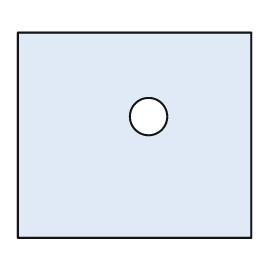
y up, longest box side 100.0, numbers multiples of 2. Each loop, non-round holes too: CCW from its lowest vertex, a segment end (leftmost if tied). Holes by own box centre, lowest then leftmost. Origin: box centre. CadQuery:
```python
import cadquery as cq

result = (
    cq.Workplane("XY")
    .moveTo(-50.0, -44.0)
    .lineTo(50.0, -44.0)
    .lineTo(50.0, 44.0)
    .lineTo(-50.0, 44.0)
    .close()
    .moveTo(6.0, 8.0)
    .circle(8.0)
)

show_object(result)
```